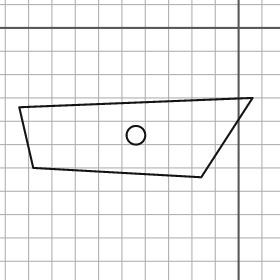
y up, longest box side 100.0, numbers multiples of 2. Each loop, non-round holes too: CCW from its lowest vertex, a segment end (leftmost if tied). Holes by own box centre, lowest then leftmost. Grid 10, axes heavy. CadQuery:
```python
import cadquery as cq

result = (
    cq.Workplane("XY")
    .moveTo(-16.0, -64.0)
    .lineTo(6.0, -30.0)
    .lineTo(-94.0, -34.0)
    .lineTo(-88.0, -60.0)
    .close()
    .moveTo(-44.0, -46.0)
    .circle(4.0)
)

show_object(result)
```